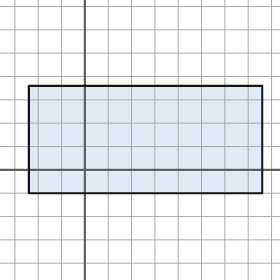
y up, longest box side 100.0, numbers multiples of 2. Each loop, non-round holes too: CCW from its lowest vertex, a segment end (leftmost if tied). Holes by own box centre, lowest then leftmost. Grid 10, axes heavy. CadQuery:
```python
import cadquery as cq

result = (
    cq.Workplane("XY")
    .moveTo(-24.0, -10.0)
    .lineTo(76.0, -10.0)
    .lineTo(76.0, 36.0)
    .lineTo(-24.0, 36.0)
    .close()
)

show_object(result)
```